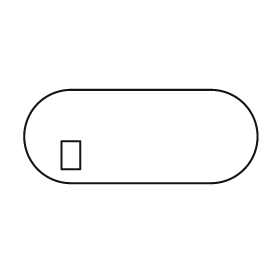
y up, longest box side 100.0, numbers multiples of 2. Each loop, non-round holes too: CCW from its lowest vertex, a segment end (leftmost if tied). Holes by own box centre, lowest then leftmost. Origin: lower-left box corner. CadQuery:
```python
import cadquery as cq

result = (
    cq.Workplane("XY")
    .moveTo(20.0, 0.0)
    .lineTo(80.0, 0.0)
    .threePointArc((100.0, 20.0), (80.0, 40.0))
    .lineTo(20.0, 40.0)
    .threePointArc((0.0, 20.0), (20.0, 0.0))
    .close()
    .moveTo(16.0, 6.0)
    .lineTo(24.0, 6.0)
    .lineTo(24.0, 18.0)
    .lineTo(16.0, 18.0)
    .close()
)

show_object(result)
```